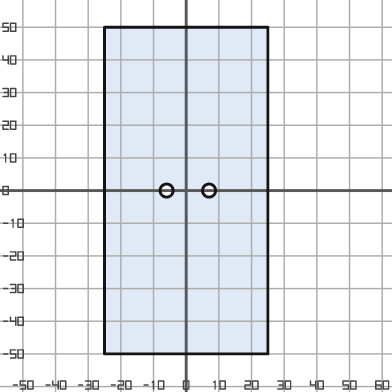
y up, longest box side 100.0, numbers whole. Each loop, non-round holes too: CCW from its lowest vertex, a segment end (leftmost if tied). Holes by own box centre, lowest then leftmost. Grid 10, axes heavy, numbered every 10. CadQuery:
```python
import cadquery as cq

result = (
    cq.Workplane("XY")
    .moveTo(-25.0, -50.0)
    .lineTo(25.0, -50.0)
    .lineTo(25.0, 50.0)
    .lineTo(-25.0, 50.0)
    .close()
    .moveTo(-6.0, 0.0)
    .circle(2.0)
    .moveTo(7.0, 0.0)
    .circle(2.0)
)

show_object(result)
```